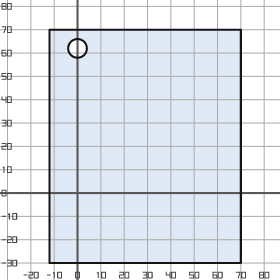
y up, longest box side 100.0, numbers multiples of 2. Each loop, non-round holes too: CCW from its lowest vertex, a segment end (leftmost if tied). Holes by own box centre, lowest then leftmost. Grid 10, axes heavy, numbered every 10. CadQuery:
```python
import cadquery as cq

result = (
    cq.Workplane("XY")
    .moveTo(-12.0, -30.0)
    .lineTo(70.0, -30.0)
    .lineTo(70.0, 70.0)
    .lineTo(-12.0, 70.0)
    .close()
    .moveTo(0.0, 62.0)
    .circle(4.0)
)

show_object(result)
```